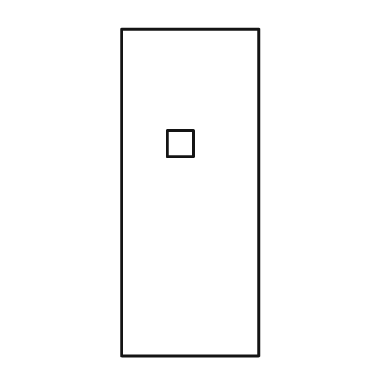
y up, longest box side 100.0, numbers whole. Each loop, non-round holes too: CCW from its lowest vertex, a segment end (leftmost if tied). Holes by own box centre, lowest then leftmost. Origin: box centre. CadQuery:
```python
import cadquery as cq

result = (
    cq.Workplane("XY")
    .moveTo(-21.0, -50.0)
    .lineTo(21.0, -50.0)
    .lineTo(21.0, 50.0)
    .lineTo(-21.0, 50.0)
    .close()
    .moveTo(-7.0, 11.0)
    .lineTo(1.0, 11.0)
    .lineTo(1.0, 19.0)
    .lineTo(-7.0, 19.0)
    .close()
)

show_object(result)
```